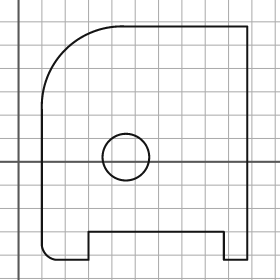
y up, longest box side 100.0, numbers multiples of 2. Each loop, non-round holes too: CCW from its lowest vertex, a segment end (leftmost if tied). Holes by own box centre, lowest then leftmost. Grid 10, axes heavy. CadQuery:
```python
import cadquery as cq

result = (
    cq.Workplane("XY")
    .moveTo(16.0, -42.0)
    .lineTo(30.0, -42.0)
    .lineTo(30.0, -30.0)
    .lineTo(88.0, -30.0)
    .lineTo(88.0, -42.0)
    .lineTo(98.0, -42.0)
    .lineTo(98.0, 58.0)
    .lineTo(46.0, 58.0)
    .threePointArc((20.0, 48.0), (10.0, 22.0))
    .lineTo(10.0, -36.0)
    .threePointArc((12.0, -40.0), (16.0, -42.0))
    .close()
    .moveTo(46.0, 2.0)
    .circle(10.0)
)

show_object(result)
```